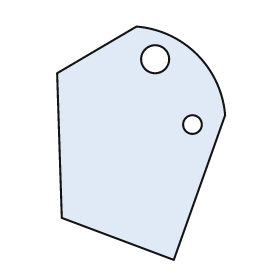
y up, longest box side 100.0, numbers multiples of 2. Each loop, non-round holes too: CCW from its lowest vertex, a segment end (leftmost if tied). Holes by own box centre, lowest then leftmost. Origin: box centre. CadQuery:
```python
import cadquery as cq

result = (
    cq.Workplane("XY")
    .moveTo(14.0, -50.0)
    .lineTo(36.0, 12.0)
    .threePointArc((24.0, 38.0), (-2.0, 50.0))
    .lineTo(-36.0, 30.0)
    .lineTo(-34.0, -32.0)
    .close()
    .moveTo(22.0, 8.0)
    .circle(4.0)
    .moveTo(6.0, 36.0)
    .circle(6.0)
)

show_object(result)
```